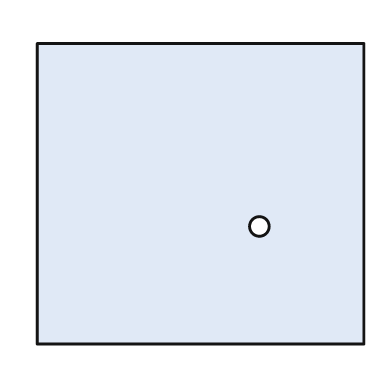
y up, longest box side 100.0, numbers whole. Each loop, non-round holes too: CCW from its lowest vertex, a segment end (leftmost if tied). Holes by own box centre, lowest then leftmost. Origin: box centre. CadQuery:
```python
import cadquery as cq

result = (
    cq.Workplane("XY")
    .moveTo(-50.0, -46.0)
    .lineTo(50.0, -46.0)
    .lineTo(50.0, 46.0)
    .lineTo(-50.0, 46.0)
    .close()
    .moveTo(18.0, -10.0)
    .circle(3.0)
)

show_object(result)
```